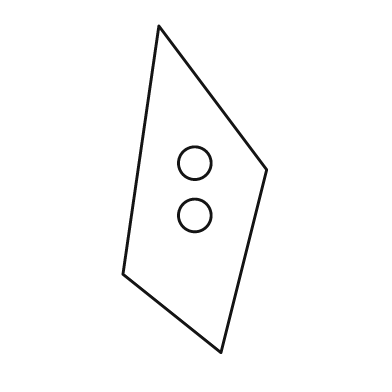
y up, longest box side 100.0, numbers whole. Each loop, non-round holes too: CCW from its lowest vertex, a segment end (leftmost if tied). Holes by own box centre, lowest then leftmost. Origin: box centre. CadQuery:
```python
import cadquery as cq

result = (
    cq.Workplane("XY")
    .moveTo(8.0, -50.0)
    .lineTo(22.0, 6.0)
    .lineTo(-11.0, 50.0)
    .lineTo(-22.0, -26.0)
    .close()
    .moveTo(0.0, -8.0)
    .circle(5.0)
    .moveTo(0.0, 8.0)
    .circle(5.0)
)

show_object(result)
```